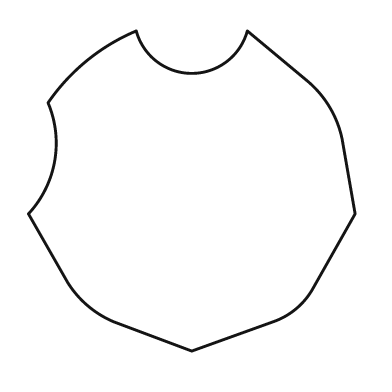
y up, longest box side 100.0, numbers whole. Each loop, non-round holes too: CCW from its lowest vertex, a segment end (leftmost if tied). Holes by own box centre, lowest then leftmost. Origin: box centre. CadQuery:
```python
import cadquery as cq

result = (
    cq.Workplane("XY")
    .moveTo(0.0, -49.0)
    .lineTo(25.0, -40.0)
    .threePointArc((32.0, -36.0), (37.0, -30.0))
    .lineTo(50.0, -7.0)
    .lineTo(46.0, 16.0)
    .threePointArc((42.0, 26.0), (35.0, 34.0))
    .lineTo(17.0, 49.0)
    .threePointArc((0.0, 36.0), (-17.0, 49.0))
    .threePointArc((-32.0, 40.0), (-44.0, 27.0))
    .threePointArc((-42.0, 9.0), (-50.0, -7.0))
    .lineTo(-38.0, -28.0)
    .threePointArc((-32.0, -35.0), (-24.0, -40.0))
    .close()
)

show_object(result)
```